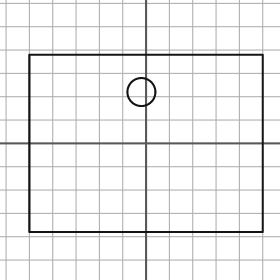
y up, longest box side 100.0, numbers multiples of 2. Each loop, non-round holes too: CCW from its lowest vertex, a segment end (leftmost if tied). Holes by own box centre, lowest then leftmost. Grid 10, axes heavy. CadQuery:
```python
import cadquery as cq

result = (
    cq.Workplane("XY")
    .moveTo(-50.0, -38.0)
    .lineTo(50.0, -38.0)
    .lineTo(50.0, 38.0)
    .lineTo(-50.0, 38.0)
    .close()
    .moveTo(-2.0, 22.0)
    .circle(6.0)
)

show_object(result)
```